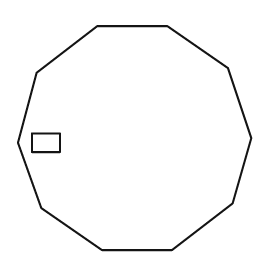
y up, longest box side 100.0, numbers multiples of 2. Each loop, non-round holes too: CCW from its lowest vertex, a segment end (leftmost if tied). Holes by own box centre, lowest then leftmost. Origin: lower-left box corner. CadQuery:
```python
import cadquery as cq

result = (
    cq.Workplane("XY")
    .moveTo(36.0, 0.0)
    .lineTo(66.0, 0.0)
    .lineTo(92.0, 20.0)
    .lineTo(100.0, 48.0)
    .lineTo(90.0, 78.0)
    .lineTo(64.0, 96.0)
    .lineTo(34.0, 96.0)
    .lineTo(8.0, 76.0)
    .lineTo(0.0, 46.0)
    .lineTo(10.0, 18.0)
    .close()
    .moveTo(6.0, 42.0)
    .lineTo(18.0, 42.0)
    .lineTo(18.0, 50.0)
    .lineTo(6.0, 50.0)
    .close()
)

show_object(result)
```